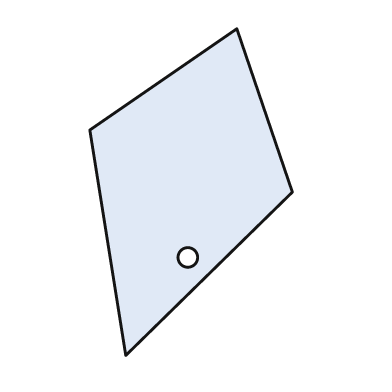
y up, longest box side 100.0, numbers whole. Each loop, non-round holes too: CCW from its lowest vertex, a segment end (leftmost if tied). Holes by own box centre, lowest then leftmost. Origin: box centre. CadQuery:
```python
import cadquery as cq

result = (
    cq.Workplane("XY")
    .moveTo(-20.0, -50.0)
    .lineTo(31.0, 0.0)
    .lineTo(14.0, 50.0)
    .lineTo(-31.0, 19.0)
    .close()
    .moveTo(-1.0, -20.0)
    .circle(3.0)
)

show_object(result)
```